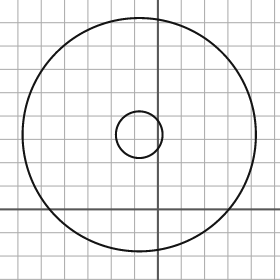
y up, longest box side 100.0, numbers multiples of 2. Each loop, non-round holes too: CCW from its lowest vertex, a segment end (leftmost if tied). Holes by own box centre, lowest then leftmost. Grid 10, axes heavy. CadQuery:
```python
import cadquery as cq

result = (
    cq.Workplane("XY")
    .moveTo(-8.0, 32.0)
    .circle(50.0)
    .moveTo(-8.0, 32.0)
    .circle(10.0)
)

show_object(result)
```